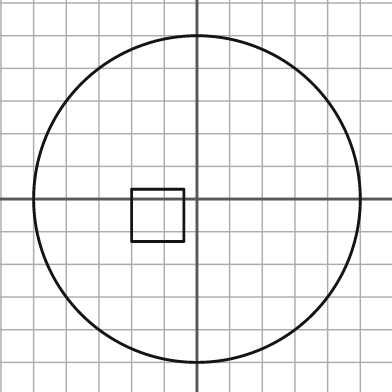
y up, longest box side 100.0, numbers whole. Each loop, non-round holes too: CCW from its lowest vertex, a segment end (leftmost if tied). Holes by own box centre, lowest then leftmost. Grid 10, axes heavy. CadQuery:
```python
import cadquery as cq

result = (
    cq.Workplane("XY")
    .moveTo(0.0, 0.0)
    .circle(50.0)
    .moveTo(-20.0, -13.0)
    .lineTo(-4.0, -13.0)
    .lineTo(-4.0, 3.0)
    .lineTo(-20.0, 3.0)
    .close()
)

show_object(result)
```